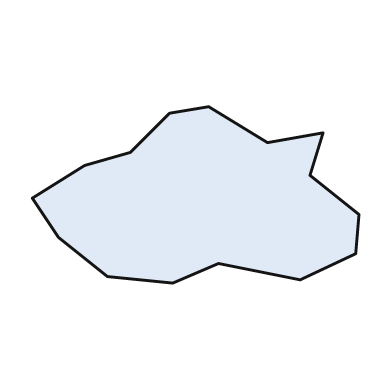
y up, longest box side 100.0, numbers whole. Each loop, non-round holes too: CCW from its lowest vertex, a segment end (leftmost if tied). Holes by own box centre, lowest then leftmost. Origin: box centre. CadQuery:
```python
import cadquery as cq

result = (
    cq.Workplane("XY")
    .moveTo(-7.0, -27.0)
    .lineTo(7.0, -21.0)
    .lineTo(32.0, -26.0)
    .lineTo(49.0, -18.0)
    .lineTo(50.0, -6.0)
    .lineTo(35.0, 6.0)
    .lineTo(39.0, 19.0)
    .lineTo(22.0, 16.0)
    .lineTo(4.0, 27.0)
    .lineTo(-8.0, 25.0)
    .lineTo(-20.0, 13.0)
    .lineTo(-34.0, 9.0)
    .lineTo(-50.0, -1.0)
    .lineTo(-42.0, -13.0)
    .lineTo(-27.0, -25.0)
    .close()
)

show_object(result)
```